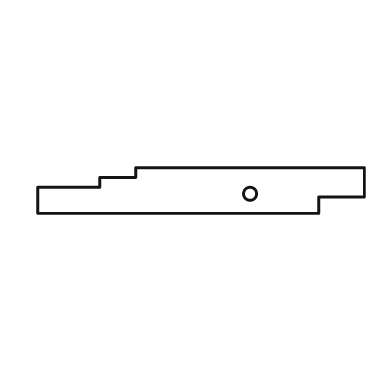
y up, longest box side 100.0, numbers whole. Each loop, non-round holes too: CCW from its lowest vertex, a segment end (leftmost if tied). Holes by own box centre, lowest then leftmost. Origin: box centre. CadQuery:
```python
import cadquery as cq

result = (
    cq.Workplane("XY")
    .moveTo(-50.0, -7.0)
    .lineTo(36.0, -7.0)
    .lineTo(36.0, -2.0)
    .lineTo(50.0, -2.0)
    .lineTo(50.0, 7.0)
    .lineTo(-20.0, 7.0)
    .lineTo(-20.0, 4.0)
    .lineTo(-31.0, 4.0)
    .lineTo(-31.0, 1.0)
    .lineTo(-50.0, 1.0)
    .close()
    .moveTo(15.0, -1.0)
    .circle(2.0)
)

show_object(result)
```